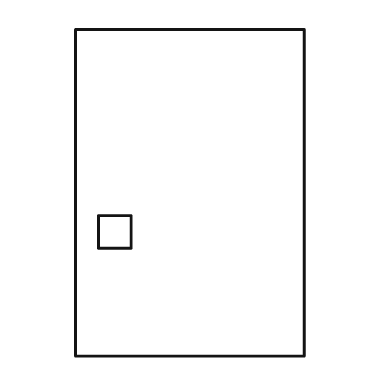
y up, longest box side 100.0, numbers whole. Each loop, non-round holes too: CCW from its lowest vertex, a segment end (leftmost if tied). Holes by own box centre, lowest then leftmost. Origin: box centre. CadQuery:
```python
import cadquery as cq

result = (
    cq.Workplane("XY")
    .moveTo(-35.0, -50.0)
    .lineTo(35.0, -50.0)
    .lineTo(35.0, 50.0)
    .lineTo(-35.0, 50.0)
    .close()
    .moveTo(-28.0, -17.0)
    .lineTo(-18.0, -17.0)
    .lineTo(-18.0, -7.0)
    .lineTo(-28.0, -7.0)
    .close()
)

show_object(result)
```